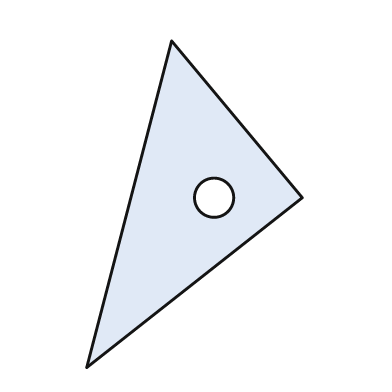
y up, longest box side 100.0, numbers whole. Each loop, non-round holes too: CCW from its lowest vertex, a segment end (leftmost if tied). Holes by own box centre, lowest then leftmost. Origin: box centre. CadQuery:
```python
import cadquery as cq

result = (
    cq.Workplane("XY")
    .moveTo(-33.0, -50.0)
    .lineTo(33.0, 2.0)
    .lineTo(-7.0, 50.0)
    .close()
    .moveTo(6.0, 2.0)
    .circle(6.0)
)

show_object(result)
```